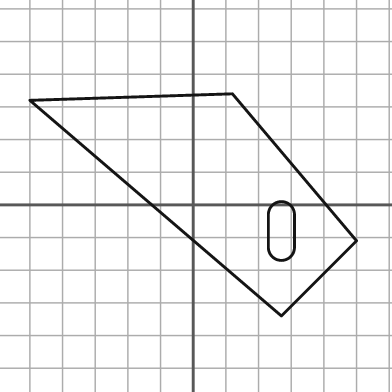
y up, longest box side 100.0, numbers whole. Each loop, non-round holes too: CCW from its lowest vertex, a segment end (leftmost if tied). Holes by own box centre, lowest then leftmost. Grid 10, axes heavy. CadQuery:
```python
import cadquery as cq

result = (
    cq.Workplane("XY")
    .moveTo(27.0, -34.0)
    .lineTo(50.0, -11.0)
    .lineTo(12.0, 34.0)
    .lineTo(-50.0, 32.0)
    .close()
    .moveTo(23.0, -13.0)
    .threePointArc((27.0, -17.0), (31.0, -13.0))
    .lineTo(31.0, -3.0)
    .threePointArc((27.0, 1.0), (23.0, -3.0))
    .close()
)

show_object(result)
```